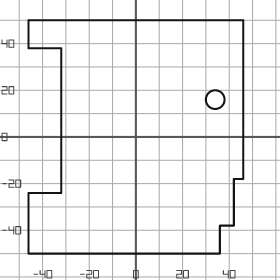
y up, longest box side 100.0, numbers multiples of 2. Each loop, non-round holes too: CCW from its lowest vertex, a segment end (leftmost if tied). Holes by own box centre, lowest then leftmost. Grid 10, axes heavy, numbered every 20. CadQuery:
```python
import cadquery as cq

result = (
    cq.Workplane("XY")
    .moveTo(-46.0, -50.0)
    .lineTo(36.0, -50.0)
    .lineTo(36.0, -38.0)
    .lineTo(42.0, -38.0)
    .lineTo(42.0, -18.0)
    .lineTo(46.0, -18.0)
    .lineTo(46.0, 50.0)
    .lineTo(-46.0, 50.0)
    .lineTo(-46.0, 38.0)
    .lineTo(-32.0, 38.0)
    .lineTo(-32.0, -24.0)
    .lineTo(-46.0, -24.0)
    .close()
    .moveTo(34.0, 16.0)
    .circle(4.0)
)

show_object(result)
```